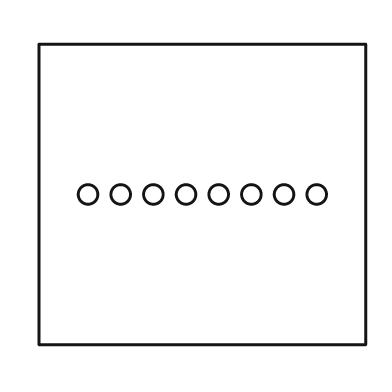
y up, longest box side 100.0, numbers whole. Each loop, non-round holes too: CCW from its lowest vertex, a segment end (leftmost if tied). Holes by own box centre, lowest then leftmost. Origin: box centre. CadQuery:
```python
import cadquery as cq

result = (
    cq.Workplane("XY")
    .moveTo(-50.0, -46.0)
    .lineTo(50.0, -46.0)
    .lineTo(50.0, 46.0)
    .lineTo(-50.0, 46.0)
    .close()
    .moveTo(-35.0, 0.0)
    .circle(3.0)
    .moveTo(-25.0, 0.0)
    .circle(3.0)
    .moveTo(-15.0, 0.0)
    .circle(3.0)
    .moveTo(-5.0, 0.0)
    .circle(3.0)
    .moveTo(5.0, 0.0)
    .circle(3.0)
    .moveTo(15.0, 0.0)
    .circle(3.0)
    .moveTo(25.0, 0.0)
    .circle(3.0)
    .moveTo(35.0, 0.0)
    .circle(3.0)
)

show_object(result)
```